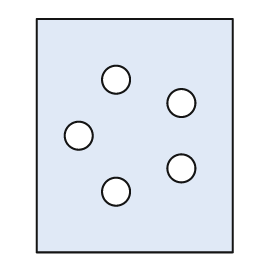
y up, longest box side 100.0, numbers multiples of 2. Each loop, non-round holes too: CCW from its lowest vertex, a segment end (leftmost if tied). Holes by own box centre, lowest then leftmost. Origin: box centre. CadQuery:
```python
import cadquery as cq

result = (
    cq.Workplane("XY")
    .moveTo(-42.0, -50.0)
    .lineTo(42.0, -50.0)
    .lineTo(42.0, 50.0)
    .lineTo(-42.0, 50.0)
    .close()
    .moveTo(-8.0, -24.0)
    .circle(6.0)
    .moveTo(20.0, -14.0)
    .circle(6.0)
    .moveTo(-24.0, 0.0)
    .circle(6.0)
    .moveTo(20.0, 14.0)
    .circle(6.0)
    .moveTo(-8.0, 24.0)
    .circle(6.0)
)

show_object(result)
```